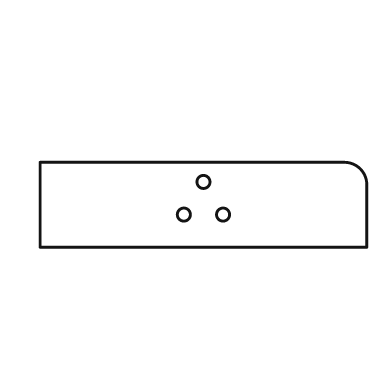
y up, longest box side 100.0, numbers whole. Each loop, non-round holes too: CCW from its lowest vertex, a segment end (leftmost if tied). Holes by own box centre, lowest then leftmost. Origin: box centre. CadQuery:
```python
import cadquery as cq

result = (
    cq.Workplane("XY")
    .moveTo(-50.0, -13.0)
    .lineTo(50.0, -13.0)
    .lineTo(50.0, 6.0)
    .threePointArc((48.0, 11.0), (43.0, 13.0))
    .lineTo(-50.0, 13.0)
    .close()
    .moveTo(-6.0, -3.0)
    .circle(2.0)
    .moveTo(6.0, -3.0)
    .circle(2.0)
    .moveTo(0.0, 7.0)
    .circle(2.0)
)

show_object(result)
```